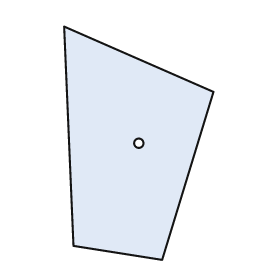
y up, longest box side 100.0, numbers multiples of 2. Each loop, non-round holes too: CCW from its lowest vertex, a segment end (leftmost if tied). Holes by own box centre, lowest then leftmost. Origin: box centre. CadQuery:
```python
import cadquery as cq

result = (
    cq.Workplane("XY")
    .moveTo(10.0, -50.0)
    .lineTo(32.0, 22.0)
    .lineTo(-32.0, 50.0)
    .lineTo(-28.0, -44.0)
    .close()
    .moveTo(0.0, 0.0)
    .circle(2.0)
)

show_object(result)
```